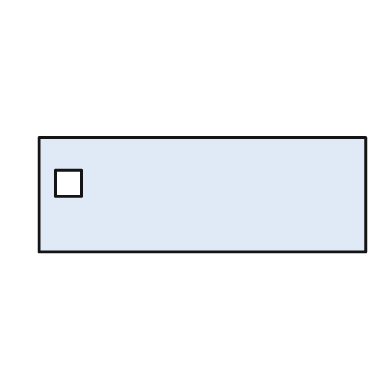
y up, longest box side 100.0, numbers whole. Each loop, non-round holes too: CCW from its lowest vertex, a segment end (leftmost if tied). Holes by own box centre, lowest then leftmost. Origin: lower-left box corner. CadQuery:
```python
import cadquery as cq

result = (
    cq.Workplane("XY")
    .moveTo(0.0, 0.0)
    .lineTo(100.0, 0.0)
    .lineTo(100.0, 35.0)
    .lineTo(0.0, 35.0)
    .close()
    .moveTo(5.0, 17.0)
    .lineTo(13.0, 17.0)
    .lineTo(13.0, 25.0)
    .lineTo(5.0, 25.0)
    .close()
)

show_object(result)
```